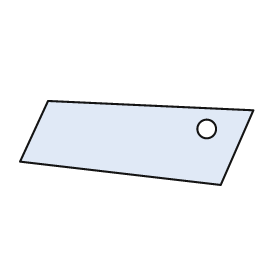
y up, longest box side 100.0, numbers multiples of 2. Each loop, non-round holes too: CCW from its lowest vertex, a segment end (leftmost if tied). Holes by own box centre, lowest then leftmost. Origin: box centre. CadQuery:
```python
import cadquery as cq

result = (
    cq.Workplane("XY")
    .moveTo(36.0, -18.0)
    .lineTo(50.0, 14.0)
    .lineTo(-38.0, 18.0)
    .lineTo(-50.0, -8.0)
    .close()
    .moveTo(30.0, 6.0)
    .circle(4.0)
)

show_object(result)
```